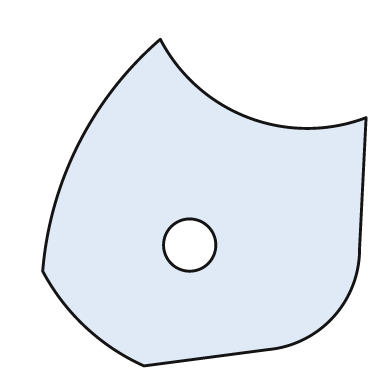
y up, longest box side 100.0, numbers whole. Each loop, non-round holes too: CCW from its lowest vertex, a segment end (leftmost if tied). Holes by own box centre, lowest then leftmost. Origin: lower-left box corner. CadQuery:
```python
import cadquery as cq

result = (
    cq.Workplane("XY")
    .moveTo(31.0, 0.0)
    .lineTo(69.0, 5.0)
    .threePointArc((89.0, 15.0), (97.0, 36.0))
    .lineTo(99.0, 76.0)
    .threePointArc((63.0, 76.0), (36.0, 100.0))
    .threePointArc((11.0, 68.0), (0.0, 29.0))
    .threePointArc((13.0, 12.0), (31.0, 0.0))
    .close()
    .moveTo(45.0, 37.0)
    .circle(8.0)
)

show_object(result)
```